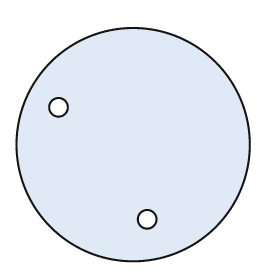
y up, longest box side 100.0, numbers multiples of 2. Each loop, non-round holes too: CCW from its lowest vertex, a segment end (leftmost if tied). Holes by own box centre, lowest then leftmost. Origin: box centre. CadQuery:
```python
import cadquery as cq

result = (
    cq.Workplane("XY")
    .moveTo(0.0, 0.0)
    .circle(50.0)
    .moveTo(6.0, -32.0)
    .circle(4.0)
    .moveTo(-32.0, 16.0)
    .circle(4.0)
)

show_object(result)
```